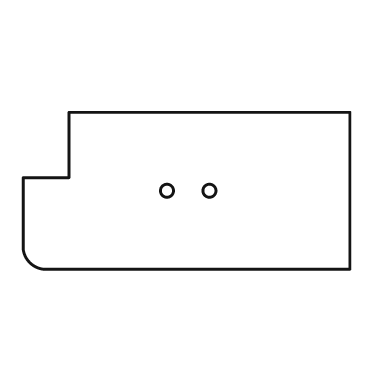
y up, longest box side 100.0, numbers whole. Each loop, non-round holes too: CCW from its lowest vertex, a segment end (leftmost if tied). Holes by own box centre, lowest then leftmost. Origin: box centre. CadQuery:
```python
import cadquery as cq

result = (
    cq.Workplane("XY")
    .moveTo(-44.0, -24.0)
    .lineTo(50.0, -24.0)
    .lineTo(50.0, 24.0)
    .lineTo(-36.0, 24.0)
    .lineTo(-36.0, 4.0)
    .lineTo(-50.0, 4.0)
    .lineTo(-50.0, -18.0)
    .threePointArc((-48.0, -22.0), (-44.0, -24.0))
    .close()
    .moveTo(-6.0, 0.0)
    .circle(2.0)
    .moveTo(7.0, 0.0)
    .circle(2.0)
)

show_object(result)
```